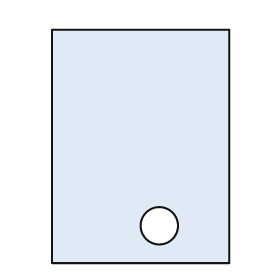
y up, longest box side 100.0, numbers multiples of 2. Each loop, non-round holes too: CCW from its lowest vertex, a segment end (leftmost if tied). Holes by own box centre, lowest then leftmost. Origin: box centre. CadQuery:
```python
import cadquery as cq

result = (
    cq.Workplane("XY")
    .moveTo(-38.0, -50.0)
    .lineTo(38.0, -50.0)
    .lineTo(38.0, 50.0)
    .lineTo(-38.0, 50.0)
    .close()
    .moveTo(8.0, -34.0)
    .circle(8.0)
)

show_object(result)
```